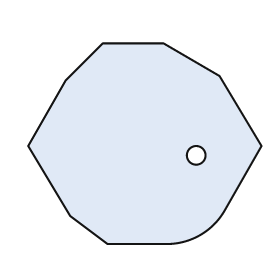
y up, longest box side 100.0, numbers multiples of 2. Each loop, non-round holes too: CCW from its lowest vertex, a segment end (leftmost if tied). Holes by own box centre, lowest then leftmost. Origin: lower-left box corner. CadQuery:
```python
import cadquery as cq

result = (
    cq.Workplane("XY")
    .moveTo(34.0, 0.0)
    .lineTo(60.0, 0.0)
    .threePointArc((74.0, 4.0), (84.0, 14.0))
    .lineTo(100.0, 42.0)
    .lineTo(82.0, 72.0)
    .lineTo(58.0, 86.0)
    .lineTo(32.0, 86.0)
    .lineTo(16.0, 70.0)
    .lineTo(0.0, 42.0)
    .lineTo(18.0, 12.0)
    .close()
    .moveTo(72.0, 38.0)
    .circle(4.0)
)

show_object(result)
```